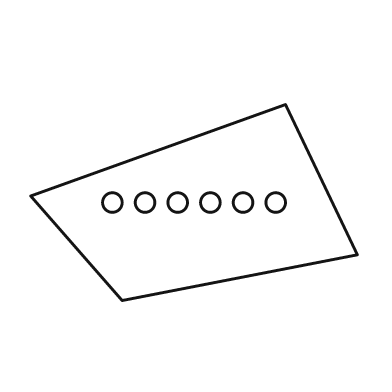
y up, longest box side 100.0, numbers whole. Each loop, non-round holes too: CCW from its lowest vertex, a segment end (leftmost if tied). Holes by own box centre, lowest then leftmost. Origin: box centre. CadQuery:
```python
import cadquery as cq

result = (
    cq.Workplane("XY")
    .moveTo(-22.0, -30.0)
    .lineTo(50.0, -16.0)
    .lineTo(28.0, 30.0)
    .lineTo(-50.0, 2.0)
    .close()
    .moveTo(-25.0, 0.0)
    .circle(3.0)
    .moveTo(-15.0, 0.0)
    .circle(3.0)
    .moveTo(-5.0, 0.0)
    .circle(3.0)
    .moveTo(5.0, 0.0)
    .circle(3.0)
    .moveTo(15.0, 0.0)
    .circle(3.0)
    .moveTo(25.0, 0.0)
    .circle(3.0)
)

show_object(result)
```